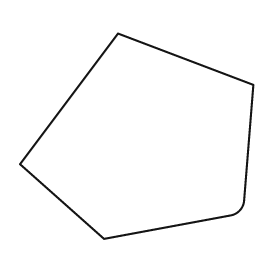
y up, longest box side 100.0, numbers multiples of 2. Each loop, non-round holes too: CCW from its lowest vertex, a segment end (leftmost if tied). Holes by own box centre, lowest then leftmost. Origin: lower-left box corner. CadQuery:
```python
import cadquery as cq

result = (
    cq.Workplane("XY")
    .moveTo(36.0, 0.0)
    .lineTo(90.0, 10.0)
    .threePointArc((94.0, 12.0), (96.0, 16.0))
    .lineTo(100.0, 66.0)
    .lineTo(42.0, 88.0)
    .lineTo(0.0, 32.0)
    .close()
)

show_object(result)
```